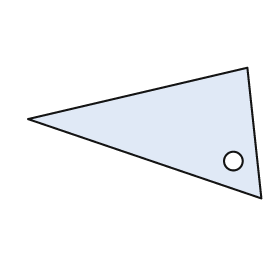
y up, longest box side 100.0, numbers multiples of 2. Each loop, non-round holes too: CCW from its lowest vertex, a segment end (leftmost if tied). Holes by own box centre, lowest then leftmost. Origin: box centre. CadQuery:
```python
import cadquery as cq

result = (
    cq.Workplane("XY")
    .moveTo(50.0, -28.0)
    .lineTo(44.0, 28.0)
    .lineTo(-50.0, 6.0)
    .close()
    .moveTo(38.0, -12.0)
    .circle(4.0)
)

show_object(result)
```